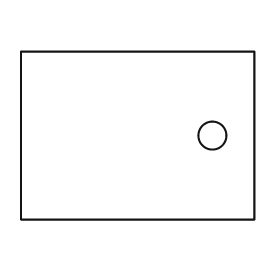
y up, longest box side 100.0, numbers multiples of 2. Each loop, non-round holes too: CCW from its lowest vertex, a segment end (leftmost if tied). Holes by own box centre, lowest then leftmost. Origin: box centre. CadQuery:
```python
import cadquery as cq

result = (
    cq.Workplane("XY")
    .moveTo(-50.0, -36.0)
    .lineTo(50.0, -36.0)
    .lineTo(50.0, 36.0)
    .lineTo(-50.0, 36.0)
    .close()
    .moveTo(32.0, 0.0)
    .circle(6.0)
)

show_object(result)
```